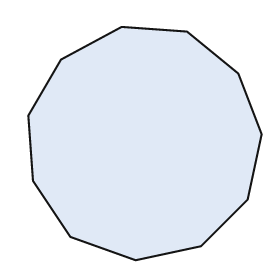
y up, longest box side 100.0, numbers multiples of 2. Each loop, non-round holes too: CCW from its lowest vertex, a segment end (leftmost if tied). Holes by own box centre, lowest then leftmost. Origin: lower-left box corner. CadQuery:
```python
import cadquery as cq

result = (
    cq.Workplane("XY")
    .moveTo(46.0, 0.0)
    .lineTo(74.0, 6.0)
    .lineTo(94.0, 26.0)
    .lineTo(100.0, 54.0)
    .lineTo(90.0, 80.0)
    .lineTo(68.0, 98.0)
    .lineTo(40.0, 100.0)
    .lineTo(14.0, 86.0)
    .lineTo(0.0, 62.0)
    .lineTo(2.0, 34.0)
    .lineTo(18.0, 10.0)
    .close()
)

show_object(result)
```